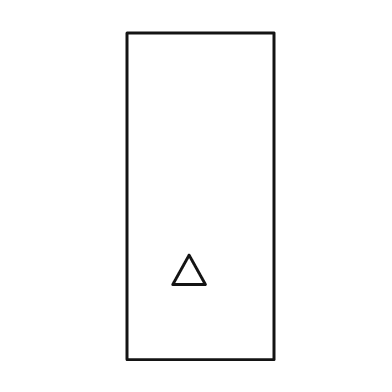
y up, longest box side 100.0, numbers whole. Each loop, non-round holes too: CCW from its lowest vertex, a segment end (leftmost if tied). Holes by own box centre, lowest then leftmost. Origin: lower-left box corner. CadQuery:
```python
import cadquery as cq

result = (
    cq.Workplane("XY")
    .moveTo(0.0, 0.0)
    .lineTo(45.0, 0.0)
    .lineTo(45.0, 100.0)
    .lineTo(0.0, 100.0)
    .close()
    .moveTo(14.0, 23.0)
    .lineTo(24.0, 23.0)
    .lineTo(19.0, 32.0)
    .close()
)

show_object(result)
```